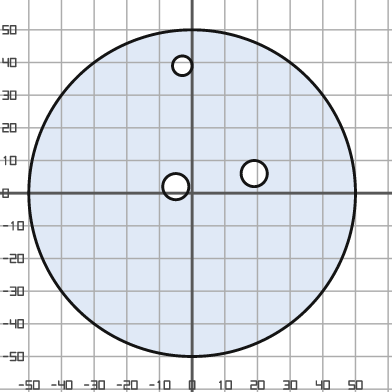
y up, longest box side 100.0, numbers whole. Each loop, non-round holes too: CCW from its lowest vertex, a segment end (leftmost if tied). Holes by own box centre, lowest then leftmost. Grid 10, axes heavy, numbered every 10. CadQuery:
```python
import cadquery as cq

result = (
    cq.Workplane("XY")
    .moveTo(0.0, 0.0)
    .circle(50.0)
    .moveTo(-5.0, 2.0)
    .circle(4.0)
    .moveTo(19.0, 6.0)
    .circle(4.0)
    .moveTo(-3.0, 39.0)
    .circle(3.0)
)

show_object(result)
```